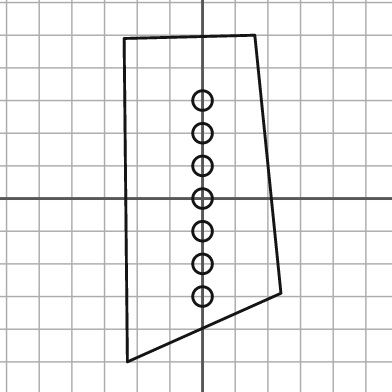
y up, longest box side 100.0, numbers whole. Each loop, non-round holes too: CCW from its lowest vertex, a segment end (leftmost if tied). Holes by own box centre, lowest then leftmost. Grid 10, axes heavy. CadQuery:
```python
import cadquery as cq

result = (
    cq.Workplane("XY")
    .moveTo(-23.0, -50.0)
    .lineTo(24.0, -29.0)
    .lineTo(16.0, 50.0)
    .lineTo(-24.0, 49.0)
    .close()
    .moveTo(0.0, -30.0)
    .circle(3.0)
    .moveTo(0.0, -20.0)
    .circle(3.0)
    .moveTo(0.0, -10.0)
    .circle(3.0)
    .moveTo(0.0, 0.0)
    .circle(3.0)
    .moveTo(0.0, 10.0)
    .circle(3.0)
    .moveTo(0.0, 20.0)
    .circle(3.0)
    .moveTo(0.0, 30.0)
    .circle(3.0)
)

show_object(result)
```